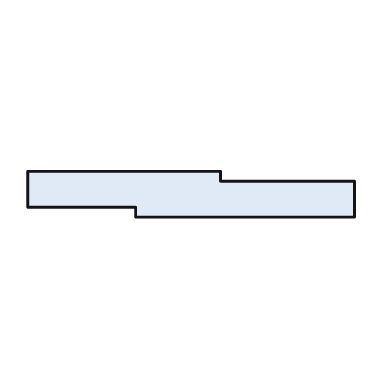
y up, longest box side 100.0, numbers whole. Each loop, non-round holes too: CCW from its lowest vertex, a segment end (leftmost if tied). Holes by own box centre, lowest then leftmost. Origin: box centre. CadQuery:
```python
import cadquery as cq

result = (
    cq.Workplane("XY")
    .moveTo(-17.0, -7.0)
    .lineTo(50.0, -7.0)
    .lineTo(50.0, 4.0)
    .lineTo(9.0, 4.0)
    .lineTo(9.0, 7.0)
    .lineTo(-50.0, 7.0)
    .lineTo(-50.0, -4.0)
    .lineTo(-17.0, -4.0)
    .close()
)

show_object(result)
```